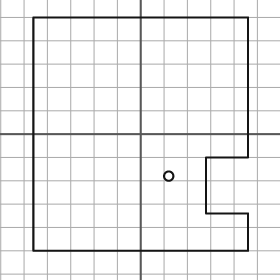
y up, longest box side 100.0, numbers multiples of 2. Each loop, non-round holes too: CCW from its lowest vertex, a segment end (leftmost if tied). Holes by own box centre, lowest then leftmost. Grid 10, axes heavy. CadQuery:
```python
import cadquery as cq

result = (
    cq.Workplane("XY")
    .moveTo(-46.0, -50.0)
    .lineTo(46.0, -50.0)
    .lineTo(46.0, -34.0)
    .lineTo(28.0, -34.0)
    .lineTo(28.0, -10.0)
    .lineTo(46.0, -10.0)
    .lineTo(46.0, 50.0)
    .lineTo(-46.0, 50.0)
    .close()
    .moveTo(12.0, -18.0)
    .circle(2.0)
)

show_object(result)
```